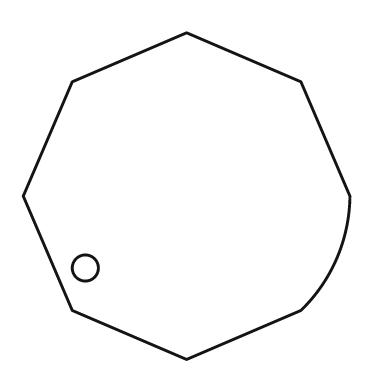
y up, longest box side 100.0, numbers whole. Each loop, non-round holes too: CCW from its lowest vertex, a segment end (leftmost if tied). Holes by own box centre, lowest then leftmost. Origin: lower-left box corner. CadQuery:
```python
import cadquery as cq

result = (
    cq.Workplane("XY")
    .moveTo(50.0, 0.0)
    .lineTo(85.0, 15.0)
    .threePointArc((96.0, 31.0), (100.0, 50.0))
    .lineTo(85.0, 85.0)
    .lineTo(50.0, 100.0)
    .lineTo(15.0, 85.0)
    .lineTo(0.0, 50.0)
    .lineTo(15.0, 15.0)
    .close()
    .moveTo(19.0, 28.0)
    .circle(4.0)
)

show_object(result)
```